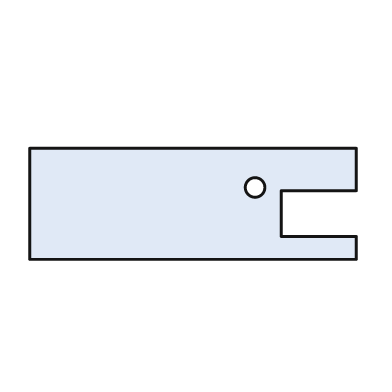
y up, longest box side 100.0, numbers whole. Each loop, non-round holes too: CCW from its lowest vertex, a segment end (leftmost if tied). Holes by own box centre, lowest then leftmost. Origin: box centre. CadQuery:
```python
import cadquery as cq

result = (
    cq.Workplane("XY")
    .moveTo(-50.0, -17.0)
    .lineTo(50.0, -17.0)
    .lineTo(50.0, -10.0)
    .lineTo(27.0, -10.0)
    .lineTo(27.0, 4.0)
    .lineTo(50.0, 4.0)
    .lineTo(50.0, 17.0)
    .lineTo(-50.0, 17.0)
    .close()
    .moveTo(19.0, 5.0)
    .circle(3.0)
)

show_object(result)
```